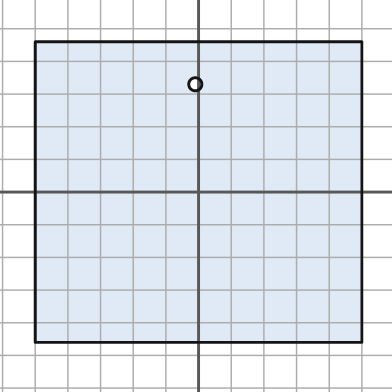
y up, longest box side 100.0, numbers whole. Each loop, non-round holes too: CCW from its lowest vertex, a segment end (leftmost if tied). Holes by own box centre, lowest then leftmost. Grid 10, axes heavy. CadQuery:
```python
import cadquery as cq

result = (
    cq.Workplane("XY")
    .moveTo(-50.0, -46.0)
    .lineTo(50.0, -46.0)
    .lineTo(50.0, 46.0)
    .lineTo(-50.0, 46.0)
    .close()
    .moveTo(-1.0, 33.0)
    .circle(2.0)
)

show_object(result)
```